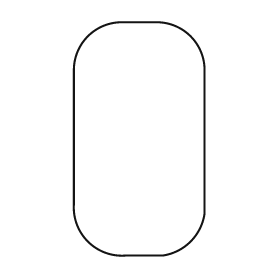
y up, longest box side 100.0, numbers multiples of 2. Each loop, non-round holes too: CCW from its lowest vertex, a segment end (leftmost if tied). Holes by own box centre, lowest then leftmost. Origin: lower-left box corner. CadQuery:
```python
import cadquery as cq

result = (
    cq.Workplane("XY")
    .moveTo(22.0, 0.0)
    .lineTo(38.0, 0.0)
    .threePointArc((50.0, 6.0), (56.0, 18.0))
    .lineTo(56.0, 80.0)
    .threePointArc((50.0, 94.0), (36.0, 100.0))
    .lineTo(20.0, 100.0)
    .threePointArc((6.0, 94.0), (0.0, 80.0))
    .lineTo(0.0, 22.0)
    .threePointArc((6.0, 6.0), (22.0, 0.0))
    .close()
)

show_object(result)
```